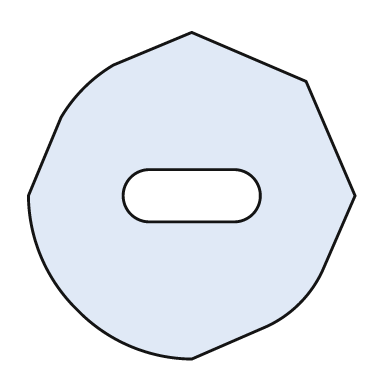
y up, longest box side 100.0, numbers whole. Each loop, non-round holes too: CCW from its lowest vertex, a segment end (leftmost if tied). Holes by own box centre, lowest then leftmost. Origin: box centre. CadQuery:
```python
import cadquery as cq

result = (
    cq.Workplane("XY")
    .moveTo(0.0, -50.0)
    .lineTo(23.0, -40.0)
    .threePointArc((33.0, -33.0), (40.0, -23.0))
    .lineTo(50.0, 0.0)
    .lineTo(35.0, 35.0)
    .lineTo(0.0, 50.0)
    .lineTo(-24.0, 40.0)
    .threePointArc((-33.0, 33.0), (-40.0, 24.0))
    .lineTo(-50.0, 0.0)
    .threePointArc((-46.0, -19.0), (-35.0, -35.0))
    .threePointArc((-19.0, -46.0), (0.0, -50.0))
    .close()
    .moveTo(-13.0, -8.0)
    .lineTo(13.0, -8.0)
    .threePointArc((21.0, 0.0), (13.0, 8.0))
    .lineTo(-13.0, 8.0)
    .threePointArc((-21.0, 0.0), (-13.0, -8.0))
    .close()
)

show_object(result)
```